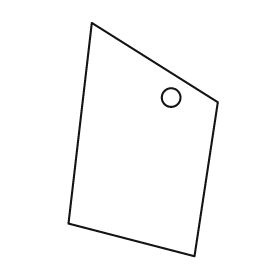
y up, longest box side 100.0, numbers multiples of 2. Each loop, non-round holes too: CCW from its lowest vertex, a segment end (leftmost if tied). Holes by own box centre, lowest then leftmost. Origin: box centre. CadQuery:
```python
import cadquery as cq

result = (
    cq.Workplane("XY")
    .moveTo(22.0, -50.0)
    .lineTo(32.0, 16.0)
    .lineTo(-22.0, 50.0)
    .lineTo(-32.0, -36.0)
    .close()
    .moveTo(12.0, 18.0)
    .circle(4.0)
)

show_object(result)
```